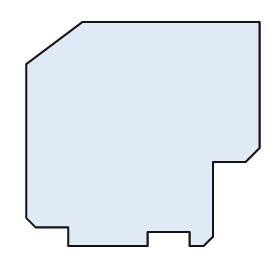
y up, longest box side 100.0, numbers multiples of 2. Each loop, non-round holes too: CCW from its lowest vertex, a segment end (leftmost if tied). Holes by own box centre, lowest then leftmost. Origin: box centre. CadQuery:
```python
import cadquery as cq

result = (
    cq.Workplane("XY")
    .moveTo(-32.0, -48.0)
    .lineTo(2.0, -48.0)
    .lineTo(2.0, -42.0)
    .lineTo(20.0, -42.0)
    .lineTo(20.0, -48.0)
    .lineTo(26.0, -48.0)
    .lineTo(30.0, -44.0)
    .lineTo(30.0, -12.0)
    .lineTo(44.0, -12.0)
    .lineTo(50.0, -6.0)
    .lineTo(50.0, 48.0)
    .lineTo(-26.0, 48.0)
    .lineTo(-50.0, 30.0)
    .lineTo(-50.0, -36.0)
    .lineTo(-46.0, -40.0)
    .lineTo(-32.0, -40.0)
    .close()
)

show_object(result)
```